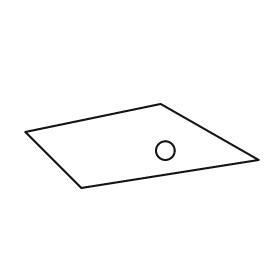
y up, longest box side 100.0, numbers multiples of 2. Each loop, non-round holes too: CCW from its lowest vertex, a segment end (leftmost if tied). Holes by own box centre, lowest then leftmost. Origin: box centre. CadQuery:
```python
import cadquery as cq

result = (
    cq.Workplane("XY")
    .moveTo(-26.0, -18.0)
    .lineTo(50.0, -6.0)
    .lineTo(8.0, 18.0)
    .lineTo(-50.0, 6.0)
    .close()
    .moveTo(10.0, -2.0)
    .circle(4.0)
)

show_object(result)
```